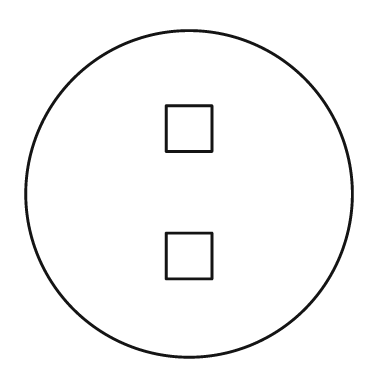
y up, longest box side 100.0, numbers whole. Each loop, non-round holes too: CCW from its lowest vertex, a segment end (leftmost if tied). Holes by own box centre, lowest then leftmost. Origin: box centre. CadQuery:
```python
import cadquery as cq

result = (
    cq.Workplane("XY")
    .moveTo(0.0, 0.0)
    .circle(50.0)
    .moveTo(-7.0, -26.0)
    .lineTo(7.0, -26.0)
    .lineTo(7.0, -12.0)
    .lineTo(-7.0, -12.0)
    .close()
    .moveTo(-7.0, 13.0)
    .lineTo(7.0, 13.0)
    .lineTo(7.0, 27.0)
    .lineTo(-7.0, 27.0)
    .close()
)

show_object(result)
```